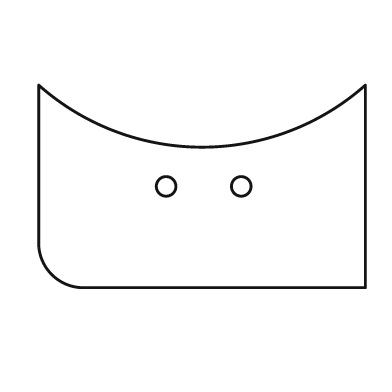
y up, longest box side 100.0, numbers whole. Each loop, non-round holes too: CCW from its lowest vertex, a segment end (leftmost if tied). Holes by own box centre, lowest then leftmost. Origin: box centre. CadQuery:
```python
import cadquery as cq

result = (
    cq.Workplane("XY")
    .moveTo(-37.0, -31.0)
    .lineTo(50.0, -31.0)
    .lineTo(50.0, 31.0)
    .threePointArc((0.0, 12.0), (-50.0, 31.0))
    .lineTo(-50.0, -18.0)
    .threePointArc((-46.0, -27.0), (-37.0, -31.0))
    .close()
    .moveTo(-11.0, 0.0)
    .circle(3.0)
    .moveTo(12.0, 0.0)
    .circle(3.0)
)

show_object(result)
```